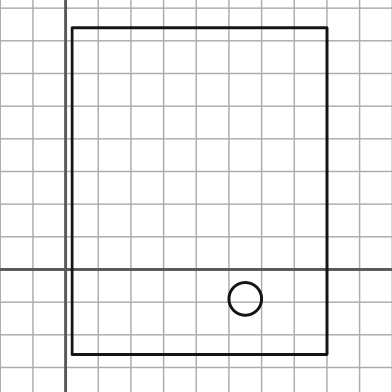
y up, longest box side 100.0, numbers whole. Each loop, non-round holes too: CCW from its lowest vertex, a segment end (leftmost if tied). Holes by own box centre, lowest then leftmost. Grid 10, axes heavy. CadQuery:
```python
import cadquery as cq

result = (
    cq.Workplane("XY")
    .moveTo(2.0, -26.0)
    .lineTo(80.0, -26.0)
    .lineTo(80.0, 74.0)
    .lineTo(2.0, 74.0)
    .close()
    .moveTo(55.0, -9.0)
    .circle(5.0)
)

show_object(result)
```